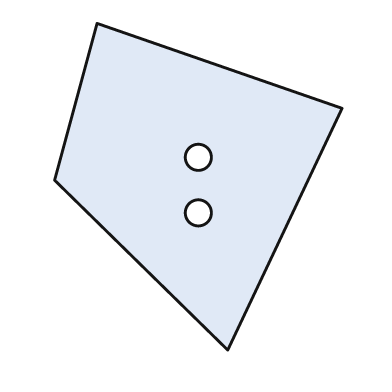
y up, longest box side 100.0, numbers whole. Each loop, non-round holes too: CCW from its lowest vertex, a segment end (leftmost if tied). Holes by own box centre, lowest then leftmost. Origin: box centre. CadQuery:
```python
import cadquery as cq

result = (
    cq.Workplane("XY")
    .moveTo(9.0, -50.0)
    .lineTo(44.0, 24.0)
    .lineTo(-31.0, 50.0)
    .lineTo(-44.0, 2.0)
    .close()
    .moveTo(0.0, -8.0)
    .circle(4.0)
    .moveTo(0.0, 9.0)
    .circle(4.0)
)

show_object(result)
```